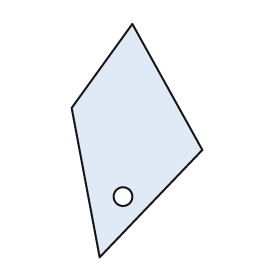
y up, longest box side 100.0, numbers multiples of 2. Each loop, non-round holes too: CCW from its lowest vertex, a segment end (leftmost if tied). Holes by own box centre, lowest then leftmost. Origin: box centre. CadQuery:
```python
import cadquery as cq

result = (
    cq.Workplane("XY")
    .moveTo(-16.0, -50.0)
    .lineTo(28.0, -4.0)
    .lineTo(-2.0, 50.0)
    .lineTo(-28.0, 14.0)
    .close()
    .moveTo(-6.0, -24.0)
    .circle(4.0)
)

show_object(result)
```